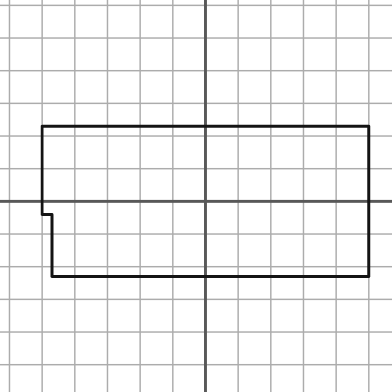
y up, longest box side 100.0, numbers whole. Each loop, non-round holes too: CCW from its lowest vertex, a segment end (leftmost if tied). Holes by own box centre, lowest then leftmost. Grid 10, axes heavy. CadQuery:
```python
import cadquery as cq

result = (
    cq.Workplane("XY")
    .moveTo(-47.0, -23.0)
    .lineTo(50.0, -23.0)
    .lineTo(50.0, 23.0)
    .lineTo(-50.0, 23.0)
    .lineTo(-50.0, -4.0)
    .lineTo(-47.0, -4.0)
    .close()
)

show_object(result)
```